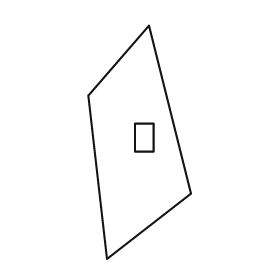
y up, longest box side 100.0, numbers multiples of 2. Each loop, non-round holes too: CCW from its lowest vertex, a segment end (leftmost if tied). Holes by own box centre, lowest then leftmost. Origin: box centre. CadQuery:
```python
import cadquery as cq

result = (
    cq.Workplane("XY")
    .moveTo(-14.0, -50.0)
    .lineTo(22.0, -22.0)
    .lineTo(4.0, 50.0)
    .lineTo(-22.0, 20.0)
    .close()
    .moveTo(-2.0, -4.0)
    .lineTo(6.0, -4.0)
    .lineTo(6.0, 8.0)
    .lineTo(-2.0, 8.0)
    .close()
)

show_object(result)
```